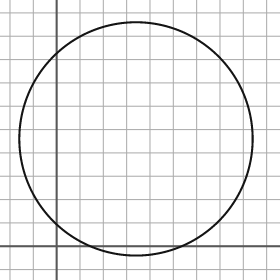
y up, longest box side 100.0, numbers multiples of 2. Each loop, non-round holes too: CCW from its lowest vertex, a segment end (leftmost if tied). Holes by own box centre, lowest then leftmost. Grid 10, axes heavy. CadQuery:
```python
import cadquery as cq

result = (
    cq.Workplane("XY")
    .moveTo(34.0, 46.0)
    .circle(50.0)
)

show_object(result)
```